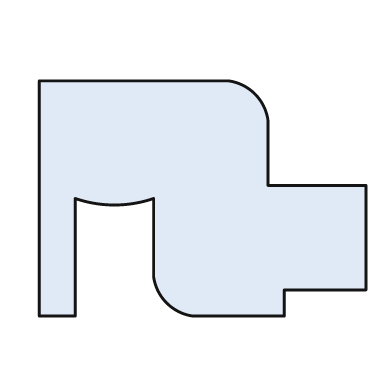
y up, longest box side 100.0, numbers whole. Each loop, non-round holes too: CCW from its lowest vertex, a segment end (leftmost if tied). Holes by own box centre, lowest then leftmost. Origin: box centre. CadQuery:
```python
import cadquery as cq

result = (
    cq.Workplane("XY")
    .moveTo(-50.0, -36.0)
    .lineTo(-39.0, -36.0)
    .lineTo(-39.0, 0.0)
    .threePointArc((-27.0, -2.0), (-15.0, 0.0))
    .lineTo(-15.0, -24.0)
    .threePointArc((-11.0, -32.0), (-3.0, -36.0))
    .lineTo(25.0, -36.0)
    .lineTo(25.0, -28.0)
    .lineTo(50.0, -28.0)
    .lineTo(50.0, 4.0)
    .lineTo(20.0, 4.0)
    .lineTo(20.0, 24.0)
    .threePointArc((16.0, 32.0), (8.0, 36.0))
    .lineTo(-50.0, 36.0)
    .close()
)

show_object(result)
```